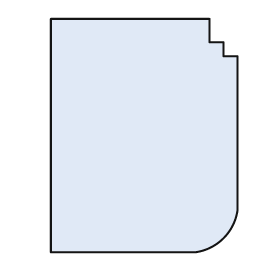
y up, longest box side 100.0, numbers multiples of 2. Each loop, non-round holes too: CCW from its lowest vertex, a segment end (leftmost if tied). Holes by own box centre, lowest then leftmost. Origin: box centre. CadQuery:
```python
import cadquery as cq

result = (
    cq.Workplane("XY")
    .moveTo(-40.0, -50.0)
    .lineTo(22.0, -50.0)
    .threePointArc((34.0, -44.0), (40.0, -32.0))
    .lineTo(40.0, 34.0)
    .lineTo(34.0, 34.0)
    .lineTo(34.0, 40.0)
    .lineTo(28.0, 40.0)
    .lineTo(28.0, 50.0)
    .lineTo(-40.0, 50.0)
    .close()
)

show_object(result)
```